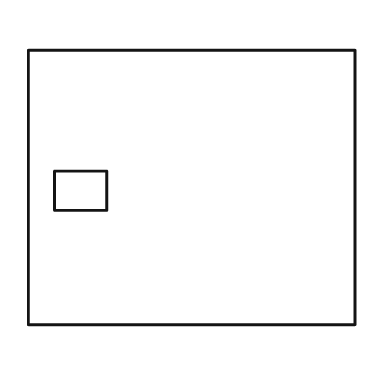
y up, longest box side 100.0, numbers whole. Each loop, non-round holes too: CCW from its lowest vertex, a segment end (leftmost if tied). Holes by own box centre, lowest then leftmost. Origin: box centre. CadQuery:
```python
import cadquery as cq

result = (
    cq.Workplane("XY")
    .moveTo(-50.0, -42.0)
    .lineTo(50.0, -42.0)
    .lineTo(50.0, 42.0)
    .lineTo(-50.0, 42.0)
    .close()
    .moveTo(-42.0, -7.0)
    .lineTo(-26.0, -7.0)
    .lineTo(-26.0, 5.0)
    .lineTo(-42.0, 5.0)
    .close()
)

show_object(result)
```